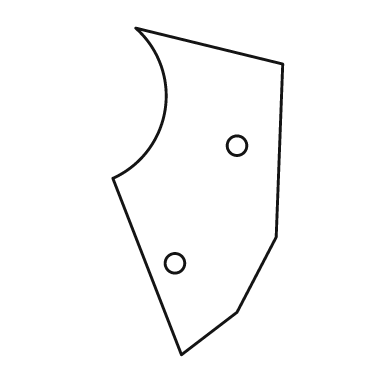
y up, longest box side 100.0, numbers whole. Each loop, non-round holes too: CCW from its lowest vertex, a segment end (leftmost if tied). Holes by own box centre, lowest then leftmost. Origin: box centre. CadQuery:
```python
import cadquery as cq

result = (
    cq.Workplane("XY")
    .moveTo(-5.0, -50.0)
    .lineTo(12.0, -37.0)
    .lineTo(24.0, -14.0)
    .lineTo(26.0, 39.0)
    .lineTo(-19.0, 50.0)
    .threePointArc((-10.0, 25.0), (-26.0, 4.0))
    .close()
    .moveTo(-7.0, -22.0)
    .circle(3.0)
    .moveTo(12.0, 14.0)
    .circle(3.0)
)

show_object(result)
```